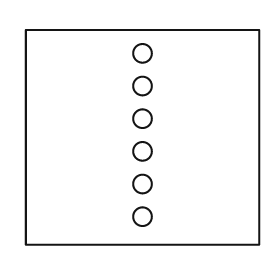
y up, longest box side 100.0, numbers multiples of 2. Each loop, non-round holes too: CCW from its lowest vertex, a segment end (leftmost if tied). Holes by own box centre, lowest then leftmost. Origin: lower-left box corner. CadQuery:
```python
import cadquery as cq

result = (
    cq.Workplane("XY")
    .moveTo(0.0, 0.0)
    .lineTo(100.0, 0.0)
    .lineTo(100.0, 92.0)
    .lineTo(0.0, 92.0)
    .close()
    .moveTo(50.0, 12.0)
    .circle(4.0)
    .moveTo(50.0, 26.0)
    .circle(4.0)
    .moveTo(50.0, 40.0)
    .circle(4.0)
    .moveTo(50.0, 54.0)
    .circle(4.0)
    .moveTo(50.0, 68.0)
    .circle(4.0)
    .moveTo(50.0, 82.0)
    .circle(4.0)
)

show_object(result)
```